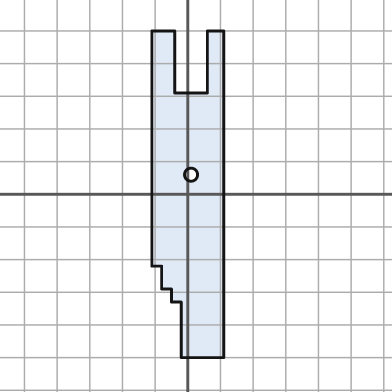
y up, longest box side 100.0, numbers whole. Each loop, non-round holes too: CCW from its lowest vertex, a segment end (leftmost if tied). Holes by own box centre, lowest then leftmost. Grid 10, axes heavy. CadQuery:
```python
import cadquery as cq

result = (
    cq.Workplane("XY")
    .moveTo(-2.0, -50.0)
    .lineTo(11.0, -50.0)
    .lineTo(11.0, 50.0)
    .lineTo(6.0, 50.0)
    .lineTo(6.0, 31.0)
    .lineTo(-4.0, 31.0)
    .lineTo(-4.0, 50.0)
    .lineTo(-11.0, 50.0)
    .lineTo(-11.0, -22.0)
    .lineTo(-8.0, -22.0)
    .lineTo(-8.0, -29.0)
    .lineTo(-5.0, -29.0)
    .lineTo(-5.0, -33.0)
    .lineTo(-2.0, -33.0)
    .close()
    .moveTo(1.0, 6.0)
    .circle(2.0)
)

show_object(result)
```